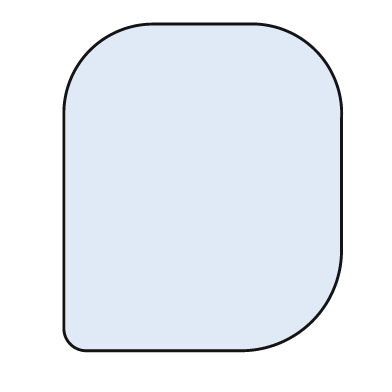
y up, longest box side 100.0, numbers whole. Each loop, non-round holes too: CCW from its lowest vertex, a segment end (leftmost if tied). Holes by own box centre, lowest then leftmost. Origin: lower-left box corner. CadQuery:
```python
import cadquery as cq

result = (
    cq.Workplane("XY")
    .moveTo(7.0, 0.0)
    .lineTo(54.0, 0.0)
    .threePointArc((76.0, 9.0), (85.0, 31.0))
    .lineTo(85.0, 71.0)
    .threePointArc((77.0, 92.0), (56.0, 100.0))
    .lineTo(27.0, 100.0)
    .threePointArc((8.0, 92.0), (0.0, 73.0))
    .lineTo(0.0, 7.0)
    .threePointArc((2.0, 2.0), (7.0, 0.0))
    .close()
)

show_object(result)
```